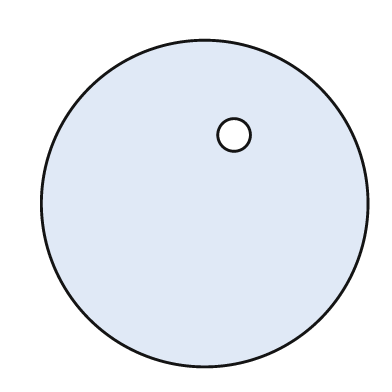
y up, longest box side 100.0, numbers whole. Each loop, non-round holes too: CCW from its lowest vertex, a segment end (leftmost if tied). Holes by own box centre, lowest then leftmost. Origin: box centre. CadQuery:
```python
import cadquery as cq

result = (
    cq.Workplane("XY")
    .moveTo(0.0, 0.0)
    .circle(50.0)
    .moveTo(9.0, 21.0)
    .circle(5.0)
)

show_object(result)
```